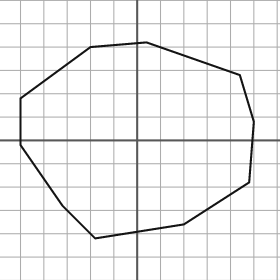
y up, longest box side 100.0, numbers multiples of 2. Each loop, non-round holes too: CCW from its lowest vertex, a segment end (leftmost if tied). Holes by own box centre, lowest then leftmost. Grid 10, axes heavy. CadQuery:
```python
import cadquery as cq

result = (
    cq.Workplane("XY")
    .moveTo(-18.0, -42.0)
    .lineTo(20.0, -36.0)
    .lineTo(48.0, -18.0)
    .lineTo(50.0, 8.0)
    .lineTo(44.0, 28.0)
    .lineTo(4.0, 42.0)
    .lineTo(-20.0, 40.0)
    .lineTo(-50.0, 18.0)
    .lineTo(-50.0, -2.0)
    .lineTo(-32.0, -28.0)
    .close()
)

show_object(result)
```